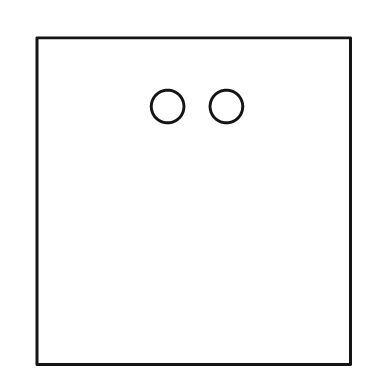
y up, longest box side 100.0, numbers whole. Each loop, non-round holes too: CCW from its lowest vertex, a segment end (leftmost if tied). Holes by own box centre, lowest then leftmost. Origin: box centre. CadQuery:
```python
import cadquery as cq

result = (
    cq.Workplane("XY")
    .moveTo(-48.0, -50.0)
    .lineTo(48.0, -50.0)
    .lineTo(48.0, 50.0)
    .lineTo(-48.0, 50.0)
    .close()
    .moveTo(-8.0, 29.0)
    .circle(5.0)
    .moveTo(10.0, 29.0)
    .circle(5.0)
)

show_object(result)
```